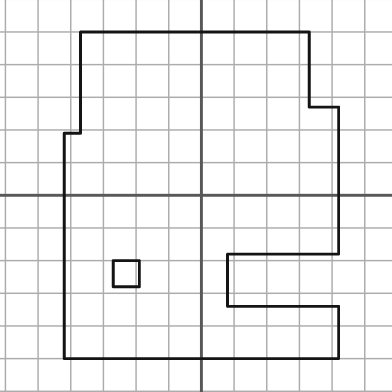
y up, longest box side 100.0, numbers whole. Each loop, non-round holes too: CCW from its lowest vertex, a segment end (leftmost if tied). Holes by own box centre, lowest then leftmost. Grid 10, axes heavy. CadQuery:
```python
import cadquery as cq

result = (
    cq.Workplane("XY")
    .moveTo(-42.0, -50.0)
    .lineTo(42.0, -50.0)
    .lineTo(42.0, -34.0)
    .lineTo(8.0, -34.0)
    .lineTo(8.0, -18.0)
    .lineTo(42.0, -18.0)
    .lineTo(42.0, 27.0)
    .lineTo(33.0, 27.0)
    .lineTo(33.0, 50.0)
    .lineTo(-37.0, 50.0)
    .lineTo(-37.0, 19.0)
    .lineTo(-42.0, 19.0)
    .close()
    .moveTo(-27.0, -28.0)
    .lineTo(-19.0, -28.0)
    .lineTo(-19.0, -20.0)
    .lineTo(-27.0, -20.0)
    .close()
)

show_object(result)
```